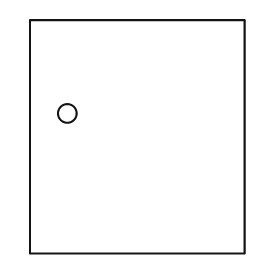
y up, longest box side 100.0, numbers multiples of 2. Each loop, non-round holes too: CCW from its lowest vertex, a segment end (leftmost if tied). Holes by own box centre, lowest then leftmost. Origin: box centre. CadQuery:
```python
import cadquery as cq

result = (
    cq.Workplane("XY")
    .moveTo(-46.0, -50.0)
    .lineTo(46.0, -50.0)
    .lineTo(46.0, 50.0)
    .lineTo(-46.0, 50.0)
    .close()
    .moveTo(-30.0, 10.0)
    .circle(4.0)
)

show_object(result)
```